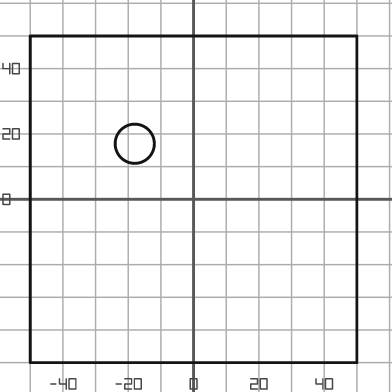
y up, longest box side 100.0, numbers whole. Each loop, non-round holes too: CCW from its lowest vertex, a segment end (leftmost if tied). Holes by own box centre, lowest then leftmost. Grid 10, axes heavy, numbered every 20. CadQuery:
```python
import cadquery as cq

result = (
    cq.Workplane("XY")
    .moveTo(-50.0, -50.0)
    .lineTo(50.0, -50.0)
    .lineTo(50.0, 50.0)
    .lineTo(-50.0, 50.0)
    .close()
    .moveTo(-18.0, 17.0)
    .circle(6.0)
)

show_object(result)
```